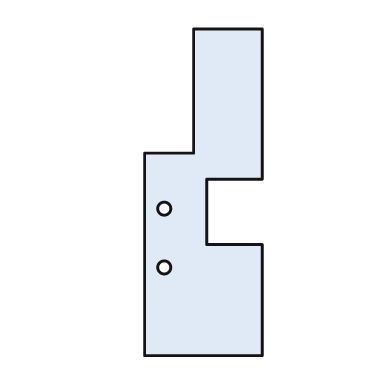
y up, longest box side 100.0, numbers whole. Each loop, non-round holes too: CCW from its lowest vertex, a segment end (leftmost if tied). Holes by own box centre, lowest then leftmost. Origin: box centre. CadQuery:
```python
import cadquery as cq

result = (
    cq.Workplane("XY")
    .moveTo(-18.0, -50.0)
    .lineTo(18.0, -50.0)
    .lineTo(18.0, -16.0)
    .lineTo(1.0, -16.0)
    .lineTo(1.0, 4.0)
    .lineTo(18.0, 4.0)
    .lineTo(18.0, 50.0)
    .lineTo(-3.0, 50.0)
    .lineTo(-3.0, 12.0)
    .lineTo(-18.0, 12.0)
    .close()
    .moveTo(-12.0, -23.0)
    .circle(2.0)
    .moveTo(-12.0, -5.0)
    .circle(2.0)
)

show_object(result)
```